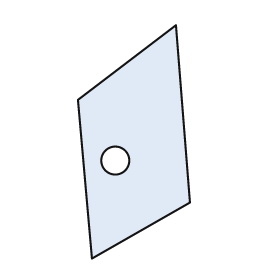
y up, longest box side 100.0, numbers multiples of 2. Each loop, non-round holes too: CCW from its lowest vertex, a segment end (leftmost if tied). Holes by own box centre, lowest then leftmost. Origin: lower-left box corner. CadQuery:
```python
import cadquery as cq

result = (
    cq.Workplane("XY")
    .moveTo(6.0, 0.0)
    .lineTo(48.0, 24.0)
    .lineTo(42.0, 100.0)
    .lineTo(0.0, 68.0)
    .close()
    .moveTo(16.0, 42.0)
    .circle(6.0)
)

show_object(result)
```